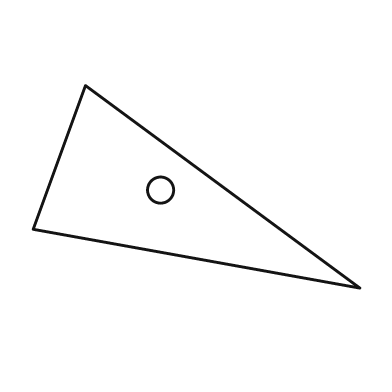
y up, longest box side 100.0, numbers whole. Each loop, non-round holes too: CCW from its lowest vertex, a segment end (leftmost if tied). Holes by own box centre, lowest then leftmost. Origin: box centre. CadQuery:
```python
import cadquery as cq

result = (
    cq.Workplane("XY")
    .moveTo(50.0, -31.0)
    .lineTo(-34.0, 31.0)
    .lineTo(-50.0, -13.0)
    .close()
    .moveTo(-11.0, -1.0)
    .circle(4.0)
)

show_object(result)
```